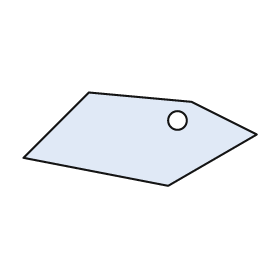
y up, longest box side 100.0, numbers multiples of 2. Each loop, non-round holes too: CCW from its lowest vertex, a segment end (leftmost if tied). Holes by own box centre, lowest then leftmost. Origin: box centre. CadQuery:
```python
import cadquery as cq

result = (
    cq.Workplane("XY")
    .moveTo(12.0, -20.0)
    .lineTo(50.0, 2.0)
    .lineTo(22.0, 16.0)
    .lineTo(-22.0, 20.0)
    .lineTo(-50.0, -8.0)
    .close()
    .moveTo(16.0, 8.0)
    .circle(4.0)
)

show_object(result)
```